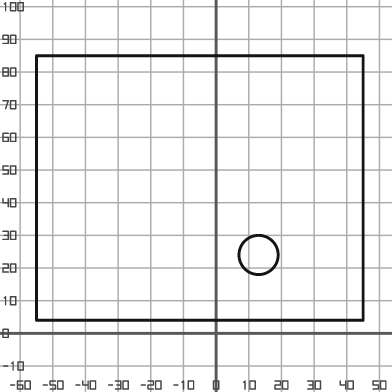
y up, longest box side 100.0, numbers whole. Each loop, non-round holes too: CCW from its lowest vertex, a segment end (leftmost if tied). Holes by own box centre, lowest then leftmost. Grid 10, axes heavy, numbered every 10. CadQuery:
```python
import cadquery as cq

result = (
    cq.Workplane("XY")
    .moveTo(-55.0, 4.0)
    .lineTo(45.0, 4.0)
    .lineTo(45.0, 85.0)
    .lineTo(-55.0, 85.0)
    .close()
    .moveTo(13.0, 24.0)
    .circle(6.0)
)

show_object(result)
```